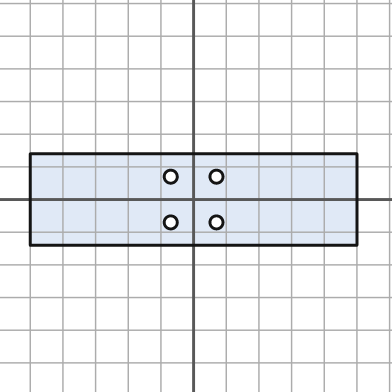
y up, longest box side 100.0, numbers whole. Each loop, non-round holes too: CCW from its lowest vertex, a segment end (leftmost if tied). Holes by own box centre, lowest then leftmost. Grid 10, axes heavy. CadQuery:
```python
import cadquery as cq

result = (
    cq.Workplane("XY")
    .moveTo(-50.0, -14.0)
    .lineTo(50.0, -14.0)
    .lineTo(50.0, 14.0)
    .lineTo(-50.0, 14.0)
    .close()
    .moveTo(-7.0, -7.0)
    .circle(2.0)
    .moveTo(7.0, -7.0)
    .circle(2.0)
    .moveTo(-7.0, 7.0)
    .circle(2.0)
    .moveTo(7.0, 7.0)
    .circle(2.0)
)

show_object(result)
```